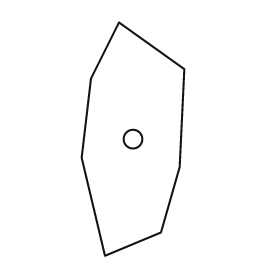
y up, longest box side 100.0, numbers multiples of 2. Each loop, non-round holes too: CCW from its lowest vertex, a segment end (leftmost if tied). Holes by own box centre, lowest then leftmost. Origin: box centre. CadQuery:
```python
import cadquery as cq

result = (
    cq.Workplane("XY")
    .moveTo(-12.0, -50.0)
    .lineTo(12.0, -40.0)
    .lineTo(20.0, -12.0)
    .lineTo(22.0, 30.0)
    .lineTo(-6.0, 50.0)
    .lineTo(-18.0, 26.0)
    .lineTo(-22.0, -8.0)
    .close()
    .moveTo(0.0, 0.0)
    .circle(4.0)
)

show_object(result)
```